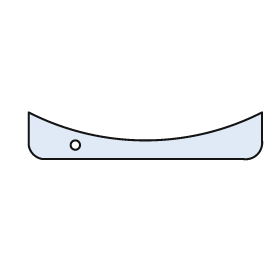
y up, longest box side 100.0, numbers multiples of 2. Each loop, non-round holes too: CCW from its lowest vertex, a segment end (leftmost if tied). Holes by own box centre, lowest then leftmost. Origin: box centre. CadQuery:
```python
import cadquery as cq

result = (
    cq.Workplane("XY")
    .moveTo(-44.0, -10.0)
    .lineTo(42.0, -10.0)
    .threePointArc((48.0, -8.0), (50.0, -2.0))
    .lineTo(50.0, 10.0)
    .threePointArc((0.0, -2.0), (-50.0, 10.0))
    .lineTo(-50.0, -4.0)
    .threePointArc((-48.0, -8.0), (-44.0, -10.0))
    .close()
    .moveTo(-30.0, -4.0)
    .circle(2.0)
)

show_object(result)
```